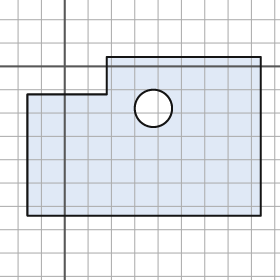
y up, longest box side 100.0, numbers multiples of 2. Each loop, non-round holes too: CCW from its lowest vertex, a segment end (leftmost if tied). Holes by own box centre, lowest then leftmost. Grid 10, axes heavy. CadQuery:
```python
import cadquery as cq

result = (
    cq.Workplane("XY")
    .moveTo(-16.0, -64.0)
    .lineTo(84.0, -64.0)
    .lineTo(84.0, 4.0)
    .lineTo(18.0, 4.0)
    .lineTo(18.0, -12.0)
    .lineTo(-16.0, -12.0)
    .close()
    .moveTo(38.0, -18.0)
    .circle(8.0)
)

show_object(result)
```